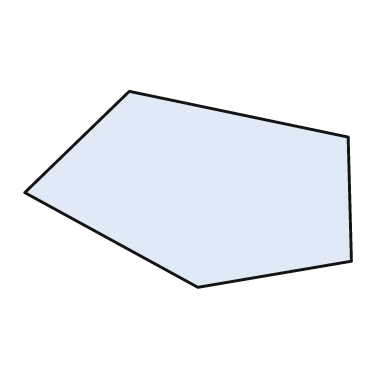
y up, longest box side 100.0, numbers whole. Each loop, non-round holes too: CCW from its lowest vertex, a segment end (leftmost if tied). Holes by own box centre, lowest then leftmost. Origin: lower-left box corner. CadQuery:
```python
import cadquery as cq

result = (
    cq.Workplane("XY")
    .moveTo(53.0, 0.0)
    .lineTo(100.0, 8.0)
    .lineTo(99.0, 46.0)
    .lineTo(32.0, 60.0)
    .lineTo(0.0, 29.0)
    .close()
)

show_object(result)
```